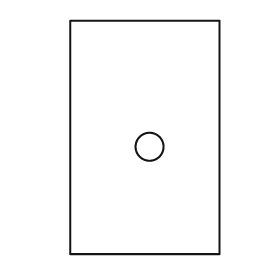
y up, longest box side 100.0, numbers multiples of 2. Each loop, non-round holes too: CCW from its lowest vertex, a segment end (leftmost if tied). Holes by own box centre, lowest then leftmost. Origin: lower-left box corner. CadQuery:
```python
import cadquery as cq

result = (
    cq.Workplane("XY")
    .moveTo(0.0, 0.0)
    .lineTo(64.0, 0.0)
    .lineTo(64.0, 100.0)
    .lineTo(0.0, 100.0)
    .close()
    .moveTo(34.0, 46.0)
    .circle(6.0)
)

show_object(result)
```